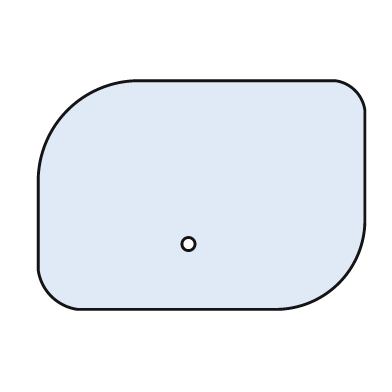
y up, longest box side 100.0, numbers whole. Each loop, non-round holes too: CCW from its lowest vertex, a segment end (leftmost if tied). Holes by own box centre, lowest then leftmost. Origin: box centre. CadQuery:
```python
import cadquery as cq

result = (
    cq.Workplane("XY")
    .moveTo(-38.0, -35.0)
    .lineTo(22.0, -35.0)
    .threePointArc((42.0, -27.0), (50.0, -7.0))
    .lineTo(50.0, 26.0)
    .threePointArc((47.0, 32.0), (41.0, 35.0))
    .lineTo(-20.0, 35.0)
    .threePointArc((-41.0, 26.0), (-50.0, 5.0))
    .lineTo(-50.0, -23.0)
    .threePointArc((-46.0, -31.0), (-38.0, -35.0))
    .close()
    .moveTo(-4.0, -15.0)
    .circle(2.0)
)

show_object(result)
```